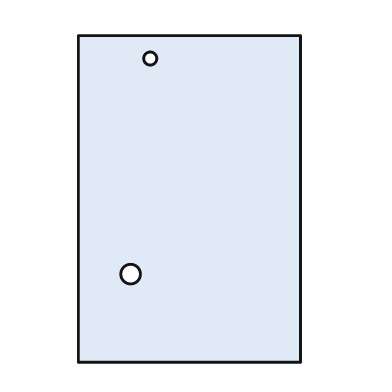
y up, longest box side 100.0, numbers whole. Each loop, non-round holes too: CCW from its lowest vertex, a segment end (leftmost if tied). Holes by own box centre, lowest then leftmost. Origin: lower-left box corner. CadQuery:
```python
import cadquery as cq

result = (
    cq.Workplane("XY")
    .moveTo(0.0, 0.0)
    .lineTo(68.0, 0.0)
    .lineTo(68.0, 100.0)
    .lineTo(0.0, 100.0)
    .close()
    .moveTo(16.0, 27.0)
    .circle(3.0)
    .moveTo(22.0, 93.0)
    .circle(2.0)
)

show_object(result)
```